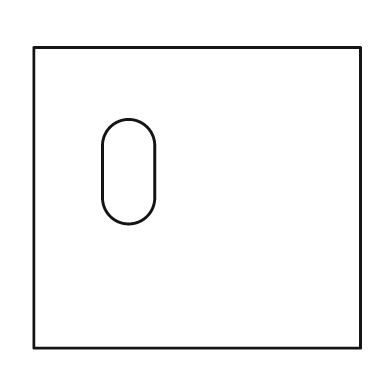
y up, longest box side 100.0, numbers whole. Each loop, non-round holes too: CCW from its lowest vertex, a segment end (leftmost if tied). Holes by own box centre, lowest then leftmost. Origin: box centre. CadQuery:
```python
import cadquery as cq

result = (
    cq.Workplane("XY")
    .moveTo(-50.0, -46.0)
    .lineTo(50.0, -46.0)
    .lineTo(50.0, 46.0)
    .lineTo(-50.0, 46.0)
    .close()
    .moveTo(-29.0, 0.0)
    .threePointArc((-21.0, -8.0), (-13.0, 0.0))
    .lineTo(-13.0, 16.0)
    .threePointArc((-21.0, 24.0), (-29.0, 16.0))
    .close()
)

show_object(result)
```